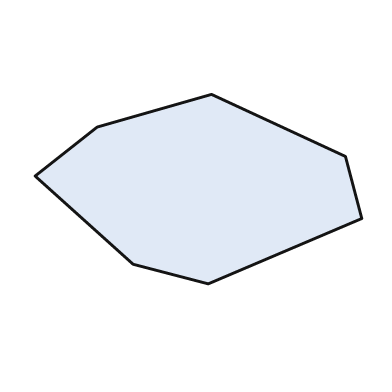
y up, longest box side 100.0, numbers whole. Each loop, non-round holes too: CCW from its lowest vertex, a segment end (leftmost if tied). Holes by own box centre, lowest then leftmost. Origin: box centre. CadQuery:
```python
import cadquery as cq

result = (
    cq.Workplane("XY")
    .moveTo(3.0, -29.0)
    .lineTo(50.0, -9.0)
    .lineTo(45.0, 10.0)
    .lineTo(4.0, 29.0)
    .lineTo(-31.0, 19.0)
    .lineTo(-50.0, 4.0)
    .lineTo(-20.0, -23.0)
    .close()
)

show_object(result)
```